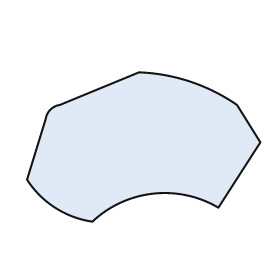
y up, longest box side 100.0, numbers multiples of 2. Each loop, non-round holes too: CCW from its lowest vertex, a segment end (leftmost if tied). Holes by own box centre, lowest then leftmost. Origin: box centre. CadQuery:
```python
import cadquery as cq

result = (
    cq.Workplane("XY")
    .moveTo(-22.0, -32.0)
    .threePointArc((4.0, -20.0), (32.0, -26.0))
    .lineTo(50.0, 2.0)
    .lineTo(40.0, 18.0)
    .threePointArc((20.0, 28.0), (-2.0, 32.0))
    .lineTo(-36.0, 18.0)
    .threePointArc((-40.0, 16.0), (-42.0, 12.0))
    .lineTo(-50.0, -14.0)
    .threePointArc((-38.0, -26.0), (-22.0, -32.0))
    .close()
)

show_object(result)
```